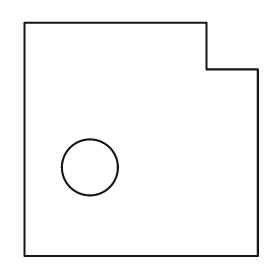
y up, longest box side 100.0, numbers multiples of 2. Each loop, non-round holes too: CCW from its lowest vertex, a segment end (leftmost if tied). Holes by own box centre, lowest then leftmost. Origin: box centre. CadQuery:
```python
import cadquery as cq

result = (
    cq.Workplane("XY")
    .moveTo(-50.0, -50.0)
    .lineTo(50.0, -50.0)
    .lineTo(50.0, 30.0)
    .lineTo(28.0, 30.0)
    .lineTo(28.0, 50.0)
    .lineTo(-50.0, 50.0)
    .close()
    .moveTo(-22.0, -12.0)
    .circle(12.0)
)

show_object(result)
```